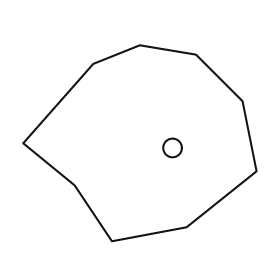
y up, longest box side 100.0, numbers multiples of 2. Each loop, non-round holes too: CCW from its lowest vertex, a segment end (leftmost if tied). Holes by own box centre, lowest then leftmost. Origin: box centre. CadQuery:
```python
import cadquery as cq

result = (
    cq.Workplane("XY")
    .moveTo(-12.0, -42.0)
    .lineTo(20.0, -36.0)
    .lineTo(50.0, -12.0)
    .lineTo(44.0, 18.0)
    .lineTo(24.0, 38.0)
    .lineTo(0.0, 42.0)
    .lineTo(-20.0, 34.0)
    .lineTo(-50.0, 0.0)
    .lineTo(-28.0, -18.0)
    .close()
    .moveTo(14.0, -2.0)
    .circle(4.0)
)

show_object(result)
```